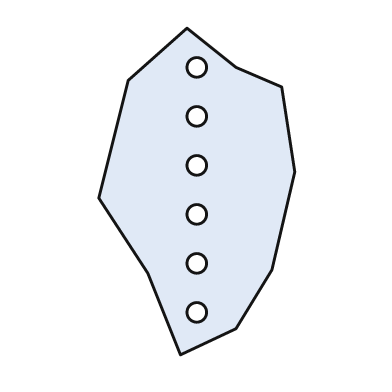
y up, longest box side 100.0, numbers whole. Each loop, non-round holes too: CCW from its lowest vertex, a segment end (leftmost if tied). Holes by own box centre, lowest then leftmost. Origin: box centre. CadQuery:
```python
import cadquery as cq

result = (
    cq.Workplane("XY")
    .moveTo(-5.0, -50.0)
    .lineTo(12.0, -42.0)
    .lineTo(23.0, -24.0)
    .lineTo(30.0, 6.0)
    .lineTo(26.0, 32.0)
    .lineTo(12.0, 38.0)
    .lineTo(-3.0, 50.0)
    .lineTo(-21.0, 34.0)
    .lineTo(-30.0, -2.0)
    .lineTo(-15.0, -25.0)
    .close()
    .moveTo(0.0, -37.0)
    .circle(3.0)
    .moveTo(0.0, -22.0)
    .circle(3.0)
    .moveTo(0.0, -7.0)
    .circle(3.0)
    .moveTo(0.0, 8.0)
    .circle(3.0)
    .moveTo(0.0, 23.0)
    .circle(3.0)
    .moveTo(0.0, 38.0)
    .circle(3.0)
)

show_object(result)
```